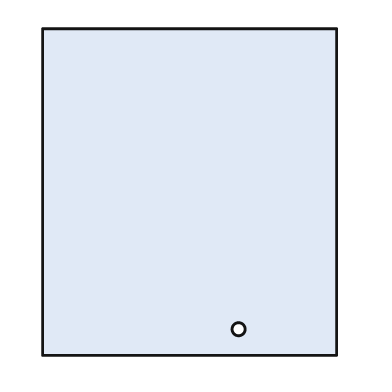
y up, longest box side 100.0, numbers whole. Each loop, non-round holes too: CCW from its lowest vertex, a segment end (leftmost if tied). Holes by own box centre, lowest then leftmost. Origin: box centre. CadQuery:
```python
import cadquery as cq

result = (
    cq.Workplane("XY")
    .moveTo(-45.0, -50.0)
    .lineTo(45.0, -50.0)
    .lineTo(45.0, 50.0)
    .lineTo(-45.0, 50.0)
    .close()
    .moveTo(15.0, -42.0)
    .circle(2.0)
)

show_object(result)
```